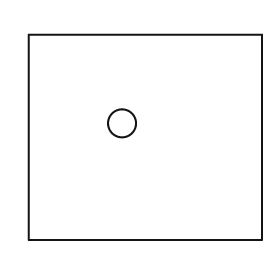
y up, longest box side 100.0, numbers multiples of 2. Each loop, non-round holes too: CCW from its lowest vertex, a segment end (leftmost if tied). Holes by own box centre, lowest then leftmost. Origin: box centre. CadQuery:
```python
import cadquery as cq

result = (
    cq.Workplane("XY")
    .moveTo(-50.0, -44.0)
    .lineTo(50.0, -44.0)
    .lineTo(50.0, 44.0)
    .lineTo(-50.0, 44.0)
    .close()
    .moveTo(-10.0, 6.0)
    .circle(6.0)
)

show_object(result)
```